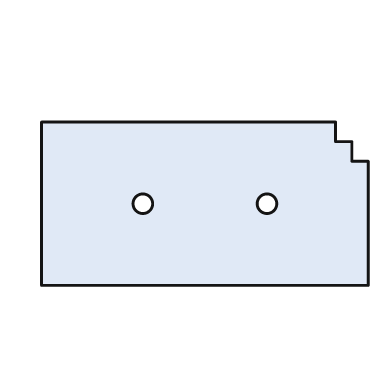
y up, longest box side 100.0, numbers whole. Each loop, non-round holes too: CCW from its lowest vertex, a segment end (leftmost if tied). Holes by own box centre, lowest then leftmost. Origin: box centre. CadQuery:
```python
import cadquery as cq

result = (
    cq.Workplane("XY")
    .moveTo(-50.0, -25.0)
    .lineTo(50.0, -25.0)
    .lineTo(50.0, 13.0)
    .lineTo(45.0, 13.0)
    .lineTo(45.0, 19.0)
    .lineTo(40.0, 19.0)
    .lineTo(40.0, 25.0)
    .lineTo(-50.0, 25.0)
    .close()
    .moveTo(-19.0, 0.0)
    .circle(3.0)
    .moveTo(19.0, 0.0)
    .circle(3.0)
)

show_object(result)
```